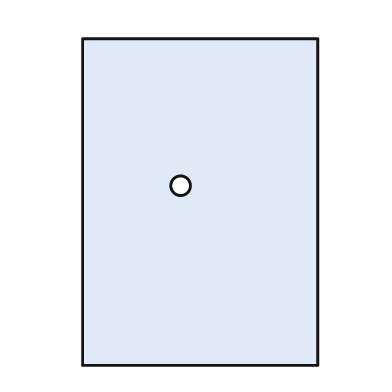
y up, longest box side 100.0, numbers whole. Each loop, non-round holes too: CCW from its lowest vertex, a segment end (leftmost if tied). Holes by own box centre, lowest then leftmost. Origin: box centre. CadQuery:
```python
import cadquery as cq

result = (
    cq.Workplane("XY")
    .moveTo(-36.0, -50.0)
    .lineTo(36.0, -50.0)
    .lineTo(36.0, 50.0)
    .lineTo(-36.0, 50.0)
    .close()
    .moveTo(-6.0, 5.0)
    .circle(3.0)
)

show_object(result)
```